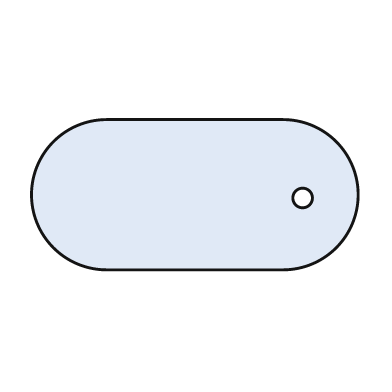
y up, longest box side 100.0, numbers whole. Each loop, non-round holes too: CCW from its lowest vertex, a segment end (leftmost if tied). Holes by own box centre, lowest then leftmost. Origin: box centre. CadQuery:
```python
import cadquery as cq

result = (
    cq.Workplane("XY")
    .moveTo(-27.0, -23.0)
    .lineTo(27.0, -23.0)
    .threePointArc((50.0, 0.0), (27.0, 23.0))
    .lineTo(-27.0, 23.0)
    .threePointArc((-50.0, 0.0), (-27.0, -23.0))
    .close()
    .moveTo(33.0, -1.0)
    .circle(3.0)
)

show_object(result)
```